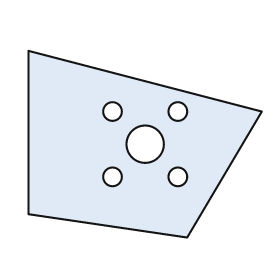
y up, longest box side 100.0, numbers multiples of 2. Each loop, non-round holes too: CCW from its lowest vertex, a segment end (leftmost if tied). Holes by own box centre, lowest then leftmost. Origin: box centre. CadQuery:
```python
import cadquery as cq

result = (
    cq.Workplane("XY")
    .moveTo(18.0, -40.0)
    .lineTo(50.0, 14.0)
    .lineTo(-50.0, 40.0)
    .lineTo(-50.0, -30.0)
    .close()
    .moveTo(-14.0, -14.0)
    .circle(4.0)
    .moveTo(14.0, -14.0)
    .circle(4.0)
    .moveTo(0.0, 0.0)
    .circle(8.0)
    .moveTo(-14.0, 14.0)
    .circle(4.0)
    .moveTo(14.0, 14.0)
    .circle(4.0)
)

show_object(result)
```